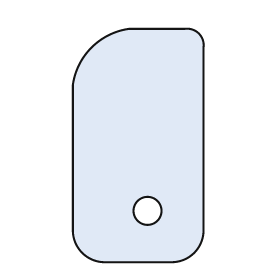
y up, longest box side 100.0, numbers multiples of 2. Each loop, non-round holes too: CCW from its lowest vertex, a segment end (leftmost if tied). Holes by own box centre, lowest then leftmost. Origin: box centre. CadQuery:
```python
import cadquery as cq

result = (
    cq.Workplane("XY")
    .moveTo(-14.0, -50.0)
    .lineTo(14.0, -50.0)
    .threePointArc((24.0, -46.0), (28.0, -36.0))
    .lineTo(28.0, 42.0)
    .threePointArc((26.0, 48.0), (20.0, 50.0))
    .lineTo(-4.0, 50.0)
    .threePointArc((-20.0, 42.0), (-28.0, 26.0))
    .lineTo(-28.0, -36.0)
    .threePointArc((-24.0, -46.0), (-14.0, -50.0))
    .close()
    .moveTo(4.0, -28.0)
    .circle(6.0)
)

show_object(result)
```